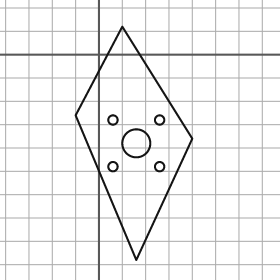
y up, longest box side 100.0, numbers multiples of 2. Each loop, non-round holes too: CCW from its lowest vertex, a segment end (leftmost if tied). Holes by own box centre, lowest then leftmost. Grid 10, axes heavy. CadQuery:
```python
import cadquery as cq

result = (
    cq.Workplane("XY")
    .moveTo(16.0, -88.0)
    .lineTo(40.0, -36.0)
    .lineTo(10.0, 12.0)
    .lineTo(-10.0, -26.0)
    .close()
    .moveTo(6.0, -48.0)
    .circle(2.0)
    .moveTo(26.0, -48.0)
    .circle(2.0)
    .moveTo(16.0, -38.0)
    .circle(6.0)
    .moveTo(6.0, -28.0)
    .circle(2.0)
    .moveTo(26.0, -28.0)
    .circle(2.0)
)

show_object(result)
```